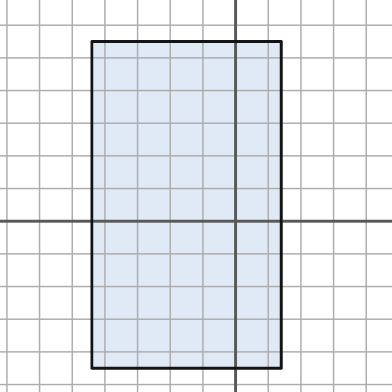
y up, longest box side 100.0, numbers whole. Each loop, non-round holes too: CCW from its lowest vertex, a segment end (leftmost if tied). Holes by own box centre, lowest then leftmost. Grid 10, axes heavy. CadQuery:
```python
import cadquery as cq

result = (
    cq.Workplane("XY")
    .moveTo(-44.0, -45.0)
    .lineTo(14.0, -45.0)
    .lineTo(14.0, 55.0)
    .lineTo(-44.0, 55.0)
    .close()
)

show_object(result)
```